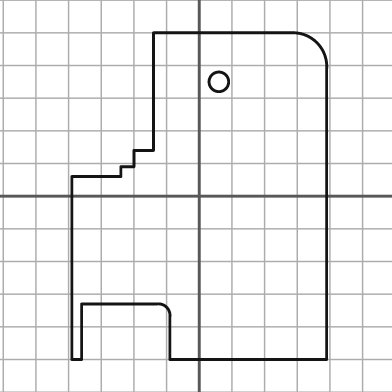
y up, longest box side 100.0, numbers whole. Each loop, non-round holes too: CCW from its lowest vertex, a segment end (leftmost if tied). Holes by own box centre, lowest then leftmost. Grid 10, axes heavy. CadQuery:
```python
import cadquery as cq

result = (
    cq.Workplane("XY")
    .moveTo(-39.0, -50.0)
    .lineTo(-36.0, -50.0)
    .lineTo(-36.0, -33.0)
    .lineTo(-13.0, -33.0)
    .threePointArc((-10.0, -34.0), (-9.0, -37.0))
    .lineTo(-9.0, -50.0)
    .lineTo(39.0, -50.0)
    .lineTo(39.0, 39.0)
    .threePointArc((36.0, 47.0), (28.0, 50.0))
    .lineTo(-14.0, 50.0)
    .lineTo(-14.0, 14.0)
    .lineTo(-20.0, 14.0)
    .lineTo(-20.0, 9.0)
    .lineTo(-24.0, 9.0)
    .lineTo(-24.0, 6.0)
    .lineTo(-39.0, 6.0)
    .close()
    .moveTo(6.0, 35.0)
    .circle(3.0)
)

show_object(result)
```